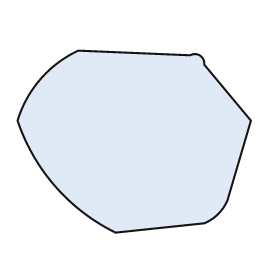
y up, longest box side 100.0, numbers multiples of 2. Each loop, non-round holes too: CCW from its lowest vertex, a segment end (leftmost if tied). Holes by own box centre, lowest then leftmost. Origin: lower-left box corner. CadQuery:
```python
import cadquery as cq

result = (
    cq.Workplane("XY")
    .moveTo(42.0, 0.0)
    .lineTo(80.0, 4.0)
    .threePointArc((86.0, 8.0), (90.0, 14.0))
    .lineTo(100.0, 48.0)
    .lineTo(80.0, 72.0)
    .threePointArc((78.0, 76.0), (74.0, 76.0))
    .lineTo(26.0, 78.0)
    .threePointArc((10.0, 66.0), (0.0, 48.0))
    .threePointArc((16.0, 20.0), (42.0, 0.0))
    .close()
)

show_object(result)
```